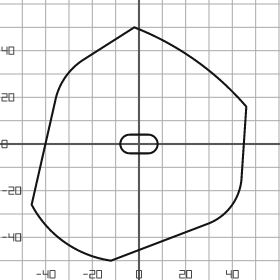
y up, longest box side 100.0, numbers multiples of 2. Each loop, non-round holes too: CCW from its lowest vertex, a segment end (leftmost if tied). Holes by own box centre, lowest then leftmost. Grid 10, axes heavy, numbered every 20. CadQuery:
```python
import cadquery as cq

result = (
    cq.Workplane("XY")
    .moveTo(-12.0, -50.0)
    .lineTo(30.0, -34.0)
    .threePointArc((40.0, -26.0), (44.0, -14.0))
    .lineTo(46.0, 16.0)
    .threePointArc((24.0, 36.0), (-2.0, 50.0))
    .lineTo(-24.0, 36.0)
    .threePointArc((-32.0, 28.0), (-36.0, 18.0))
    .lineTo(-46.0, -26.0)
    .threePointArc((-32.0, -42.0), (-12.0, -50.0))
    .close()
    .moveTo(-4.0, -4.0)
    .lineTo(4.0, -4.0)
    .threePointArc((8.0, 0.0), (4.0, 4.0))
    .lineTo(-4.0, 4.0)
    .threePointArc((-8.0, 0.0), (-4.0, -4.0))
    .close()
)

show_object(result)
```